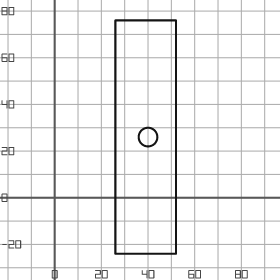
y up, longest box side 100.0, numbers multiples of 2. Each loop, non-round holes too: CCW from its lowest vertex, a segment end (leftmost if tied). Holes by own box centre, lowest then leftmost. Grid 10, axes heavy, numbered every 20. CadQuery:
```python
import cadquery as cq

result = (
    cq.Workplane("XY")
    .moveTo(26.0, -24.0)
    .lineTo(52.0, -24.0)
    .lineTo(52.0, 76.0)
    .lineTo(26.0, 76.0)
    .close()
    .moveTo(40.0, 26.0)
    .circle(4.0)
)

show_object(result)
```